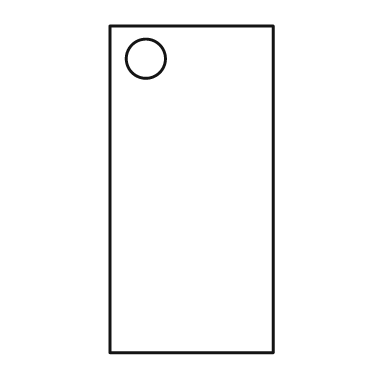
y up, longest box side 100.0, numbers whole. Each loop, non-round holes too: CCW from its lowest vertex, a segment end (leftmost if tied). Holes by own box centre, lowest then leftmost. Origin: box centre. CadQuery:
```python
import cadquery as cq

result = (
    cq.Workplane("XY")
    .moveTo(-25.0, -50.0)
    .lineTo(25.0, -50.0)
    .lineTo(25.0, 50.0)
    .lineTo(-25.0, 50.0)
    .close()
    .moveTo(-14.0, 40.0)
    .circle(6.0)
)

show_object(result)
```